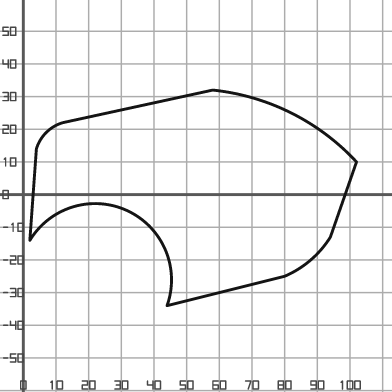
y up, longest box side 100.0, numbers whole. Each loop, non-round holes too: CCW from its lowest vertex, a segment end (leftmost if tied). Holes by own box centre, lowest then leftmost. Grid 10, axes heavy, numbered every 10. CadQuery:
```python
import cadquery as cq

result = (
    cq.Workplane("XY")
    .moveTo(44.0, -34.0)
    .lineTo(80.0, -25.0)
    .threePointArc((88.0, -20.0), (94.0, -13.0))
    .lineTo(102.0, 10.0)
    .threePointArc((82.0, 25.0), (58.0, 32.0))
    .lineTo(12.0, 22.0)
    .threePointArc((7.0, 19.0), (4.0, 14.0))
    .lineTo(2.0, -14.0)
    .threePointArc((32.0, -5.0), (44.0, -34.0))
    .close()
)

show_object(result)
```